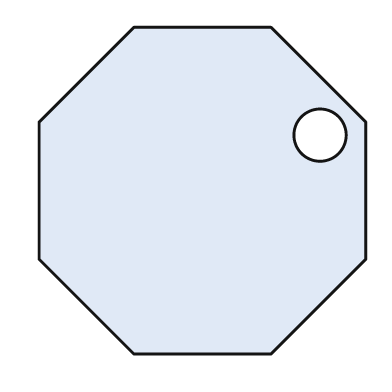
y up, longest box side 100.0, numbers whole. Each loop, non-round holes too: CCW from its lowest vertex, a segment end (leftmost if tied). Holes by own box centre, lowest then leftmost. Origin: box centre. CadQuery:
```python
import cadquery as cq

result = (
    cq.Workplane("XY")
    .moveTo(-21.0, -50.0)
    .lineTo(21.0, -50.0)
    .lineTo(50.0, -21.0)
    .lineTo(50.0, 21.0)
    .lineTo(21.0, 50.0)
    .lineTo(-21.0, 50.0)
    .lineTo(-50.0, 21.0)
    .lineTo(-50.0, -21.0)
    .close()
    .moveTo(36.0, 17.0)
    .circle(8.0)
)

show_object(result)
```